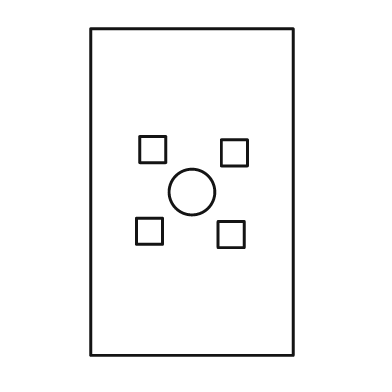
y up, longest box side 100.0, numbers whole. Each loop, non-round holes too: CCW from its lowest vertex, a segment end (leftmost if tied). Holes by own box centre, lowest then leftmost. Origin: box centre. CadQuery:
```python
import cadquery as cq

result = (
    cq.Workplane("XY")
    .moveTo(-31.0, -50.0)
    .lineTo(31.0, -50.0)
    .lineTo(31.0, 50.0)
    .lineTo(-31.0, 50.0)
    .close()
    .moveTo(8.0, -17.0)
    .lineTo(16.0, -17.0)
    .lineTo(16.0, -9.0)
    .lineTo(8.0, -9.0)
    .close()
    .moveTo(-17.0, -16.0)
    .lineTo(-9.0, -16.0)
    .lineTo(-9.0, -8.0)
    .lineTo(-17.0, -8.0)
    .close()
    .moveTo(0.0, 0.0)
    .circle(7.0)
    .moveTo(9.0, 8.0)
    .lineTo(17.0, 8.0)
    .lineTo(17.0, 16.0)
    .lineTo(9.0, 16.0)
    .close()
    .moveTo(-16.0, 9.0)
    .lineTo(-8.0, 9.0)
    .lineTo(-8.0, 17.0)
    .lineTo(-16.0, 17.0)
    .close()
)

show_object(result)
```